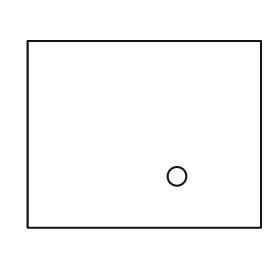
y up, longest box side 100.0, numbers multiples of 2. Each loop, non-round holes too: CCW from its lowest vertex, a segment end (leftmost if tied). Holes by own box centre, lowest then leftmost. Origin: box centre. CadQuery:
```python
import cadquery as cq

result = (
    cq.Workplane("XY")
    .moveTo(-50.0, -40.0)
    .lineTo(50.0, -40.0)
    .lineTo(50.0, 40.0)
    .lineTo(-50.0, 40.0)
    .close()
    .moveTo(14.0, -18.0)
    .circle(4.0)
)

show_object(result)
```